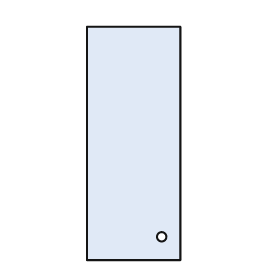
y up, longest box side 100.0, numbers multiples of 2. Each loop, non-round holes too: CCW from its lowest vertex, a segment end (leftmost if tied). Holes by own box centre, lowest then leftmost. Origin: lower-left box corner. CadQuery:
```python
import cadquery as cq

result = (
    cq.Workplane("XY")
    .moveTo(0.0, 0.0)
    .lineTo(40.0, 0.0)
    .lineTo(40.0, 100.0)
    .lineTo(0.0, 100.0)
    .close()
    .moveTo(32.0, 10.0)
    .circle(2.0)
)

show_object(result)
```